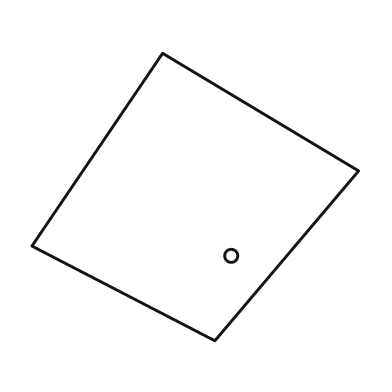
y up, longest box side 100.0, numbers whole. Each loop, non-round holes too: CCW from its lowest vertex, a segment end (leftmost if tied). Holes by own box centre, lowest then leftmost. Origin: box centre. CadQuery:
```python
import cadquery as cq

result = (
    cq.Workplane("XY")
    .moveTo(6.0, -44.0)
    .lineTo(50.0, 8.0)
    .lineTo(-10.0, 44.0)
    .lineTo(-50.0, -15.0)
    .close()
    .moveTo(11.0, -18.0)
    .circle(2.0)
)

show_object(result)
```